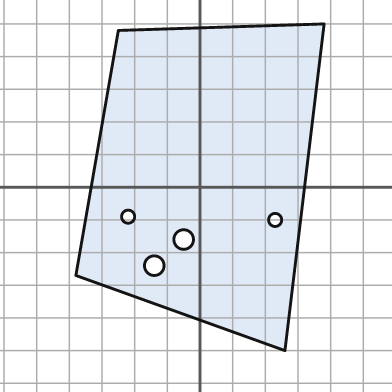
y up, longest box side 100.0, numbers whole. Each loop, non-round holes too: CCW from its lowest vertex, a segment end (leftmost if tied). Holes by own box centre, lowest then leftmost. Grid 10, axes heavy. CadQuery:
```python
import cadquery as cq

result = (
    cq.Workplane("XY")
    .moveTo(26.0, -50.0)
    .lineTo(38.0, 50.0)
    .lineTo(-25.0, 48.0)
    .lineTo(-38.0, -27.0)
    .close()
    .moveTo(-14.0, -24.0)
    .circle(3.0)
    .moveTo(-5.0, -16.0)
    .circle(3.0)
    .moveTo(23.0, -10.0)
    .circle(2.0)
    .moveTo(-22.0, -9.0)
    .circle(2.0)
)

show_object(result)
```